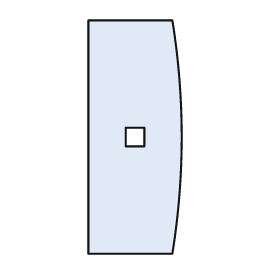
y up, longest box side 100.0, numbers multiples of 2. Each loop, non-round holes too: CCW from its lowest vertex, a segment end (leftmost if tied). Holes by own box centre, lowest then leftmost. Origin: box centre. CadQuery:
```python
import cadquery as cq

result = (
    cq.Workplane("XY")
    .moveTo(-20.0, -50.0)
    .lineTo(16.0, -50.0)
    .threePointArc((20.0, 0.0), (16.0, 50.0))
    .lineTo(-20.0, 50.0)
    .close()
    .moveTo(-4.0, -4.0)
    .lineTo(4.0, -4.0)
    .lineTo(4.0, 4.0)
    .lineTo(-4.0, 4.0)
    .close()
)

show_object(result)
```